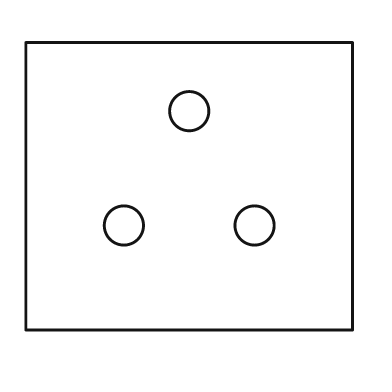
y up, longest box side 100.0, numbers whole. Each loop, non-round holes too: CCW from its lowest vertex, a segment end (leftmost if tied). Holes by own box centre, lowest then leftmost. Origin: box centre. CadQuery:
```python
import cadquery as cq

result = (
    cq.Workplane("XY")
    .moveTo(-50.0, -44.0)
    .lineTo(50.0, -44.0)
    .lineTo(50.0, 44.0)
    .lineTo(-50.0, 44.0)
    .close()
    .moveTo(-20.0, -12.0)
    .circle(6.0)
    .moveTo(20.0, -12.0)
    .circle(6.0)
    .moveTo(0.0, 23.0)
    .circle(6.0)
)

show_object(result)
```